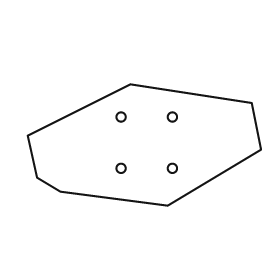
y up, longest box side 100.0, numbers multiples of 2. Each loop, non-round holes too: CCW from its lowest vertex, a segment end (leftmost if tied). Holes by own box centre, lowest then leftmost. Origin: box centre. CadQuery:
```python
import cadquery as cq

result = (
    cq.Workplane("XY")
    .moveTo(10.0, -26.0)
    .lineTo(50.0, -2.0)
    .lineTo(46.0, 18.0)
    .lineTo(-6.0, 26.0)
    .lineTo(-50.0, 4.0)
    .lineTo(-46.0, -14.0)
    .lineTo(-36.0, -20.0)
    .close()
    .moveTo(-10.0, -10.0)
    .circle(2.0)
    .moveTo(12.0, -10.0)
    .circle(2.0)
    .moveTo(-10.0, 12.0)
    .circle(2.0)
    .moveTo(12.0, 12.0)
    .circle(2.0)
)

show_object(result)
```